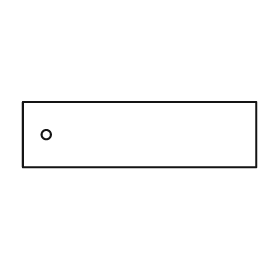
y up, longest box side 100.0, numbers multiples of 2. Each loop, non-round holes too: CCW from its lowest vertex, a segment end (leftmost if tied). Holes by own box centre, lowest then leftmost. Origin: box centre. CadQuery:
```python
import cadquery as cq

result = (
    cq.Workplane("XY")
    .moveTo(-50.0, -14.0)
    .lineTo(50.0, -14.0)
    .lineTo(50.0, 14.0)
    .lineTo(-50.0, 14.0)
    .close()
    .moveTo(-40.0, 0.0)
    .circle(2.0)
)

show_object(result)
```